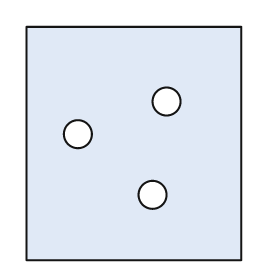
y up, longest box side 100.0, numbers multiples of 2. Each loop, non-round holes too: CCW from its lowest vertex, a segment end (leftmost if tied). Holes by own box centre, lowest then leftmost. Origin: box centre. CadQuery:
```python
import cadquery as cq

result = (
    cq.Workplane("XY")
    .moveTo(-46.0, -50.0)
    .lineTo(46.0, -50.0)
    .lineTo(46.0, 50.0)
    .lineTo(-46.0, 50.0)
    .close()
    .moveTo(8.0, -22.0)
    .circle(6.0)
    .moveTo(-24.0, 4.0)
    .circle(6.0)
    .moveTo(14.0, 18.0)
    .circle(6.0)
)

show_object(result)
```